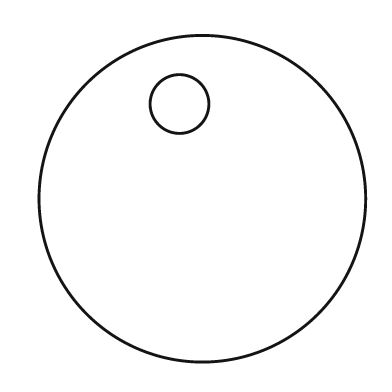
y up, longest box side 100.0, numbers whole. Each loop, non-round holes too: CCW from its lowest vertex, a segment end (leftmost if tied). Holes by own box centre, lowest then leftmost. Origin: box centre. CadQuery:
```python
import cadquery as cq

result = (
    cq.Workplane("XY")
    .moveTo(0.0, 0.0)
    .circle(50.0)
    .moveTo(-7.0, 29.0)
    .circle(9.0)
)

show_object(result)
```